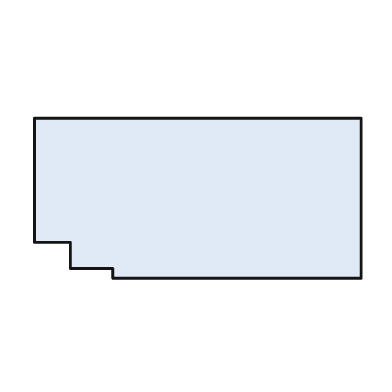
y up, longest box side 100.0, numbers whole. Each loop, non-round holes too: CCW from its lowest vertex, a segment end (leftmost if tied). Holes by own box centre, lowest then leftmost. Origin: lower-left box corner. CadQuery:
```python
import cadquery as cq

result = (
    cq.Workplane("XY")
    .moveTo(24.0, 0.0)
    .lineTo(100.0, 0.0)
    .lineTo(100.0, 49.0)
    .lineTo(0.0, 49.0)
    .lineTo(0.0, 11.0)
    .lineTo(11.0, 11.0)
    .lineTo(11.0, 3.0)
    .lineTo(24.0, 3.0)
    .close()
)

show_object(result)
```